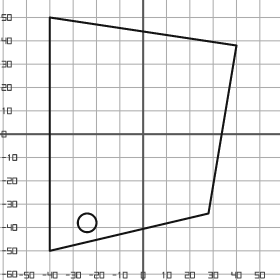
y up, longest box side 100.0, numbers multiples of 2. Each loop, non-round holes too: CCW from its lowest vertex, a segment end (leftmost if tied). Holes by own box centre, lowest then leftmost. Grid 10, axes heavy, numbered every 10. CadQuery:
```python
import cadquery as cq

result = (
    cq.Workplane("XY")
    .moveTo(-40.0, -50.0)
    .lineTo(28.0, -34.0)
    .lineTo(40.0, 38.0)
    .lineTo(-40.0, 50.0)
    .close()
    .moveTo(-24.0, -38.0)
    .circle(4.0)
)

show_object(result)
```